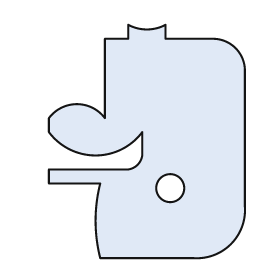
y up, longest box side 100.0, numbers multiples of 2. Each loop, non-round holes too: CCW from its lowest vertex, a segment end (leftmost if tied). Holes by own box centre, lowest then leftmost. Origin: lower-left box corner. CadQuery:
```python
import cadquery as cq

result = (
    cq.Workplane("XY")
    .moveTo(22.0, 0.0)
    .lineTo(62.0, 0.0)
    .threePointArc((78.0, 6.0), (84.0, 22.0))
    .lineTo(84.0, 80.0)
    .threePointArc((80.0, 90.0), (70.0, 94.0))
    .lineTo(50.0, 94.0)
    .lineTo(50.0, 100.0)
    .threePointArc((42.0, 98.0), (34.0, 100.0))
    .lineTo(34.0, 94.0)
    .lineTo(24.0, 94.0)
    .lineTo(24.0, 60.0)
    .threePointArc((12.0, 66.0), (0.0, 60.0))
    .lineTo(0.0, 54.0)
    .threePointArc((20.0, 44.0), (40.0, 54.0))
    .lineTo(40.0, 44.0)
    .threePointArc((38.0, 40.0), (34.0, 38.0))
    .lineTo(0.0, 38.0)
    .lineTo(0.0, 32.0)
    .lineTo(22.0, 32.0)
    .threePointArc((20.0, 16.0), (22.0, 0.0))
    .close()
    .moveTo(52.0, 30.0)
    .circle(6.0)
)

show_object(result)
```